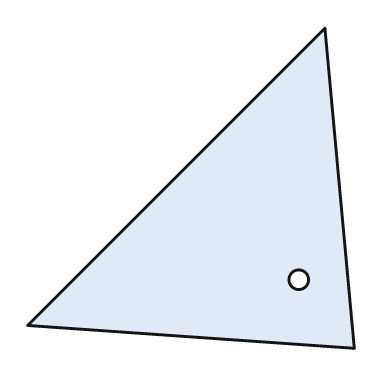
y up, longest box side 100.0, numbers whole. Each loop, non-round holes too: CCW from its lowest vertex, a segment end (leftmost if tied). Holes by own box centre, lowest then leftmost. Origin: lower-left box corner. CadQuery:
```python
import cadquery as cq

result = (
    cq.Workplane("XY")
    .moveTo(100.0, 0.0)
    .lineTo(91.0, 98.0)
    .lineTo(0.0, 7.0)
    .close()
    .moveTo(83.0, 21.0)
    .circle(3.0)
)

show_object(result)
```